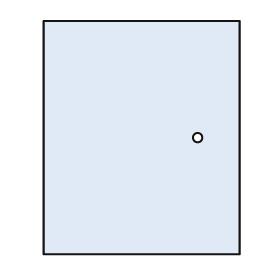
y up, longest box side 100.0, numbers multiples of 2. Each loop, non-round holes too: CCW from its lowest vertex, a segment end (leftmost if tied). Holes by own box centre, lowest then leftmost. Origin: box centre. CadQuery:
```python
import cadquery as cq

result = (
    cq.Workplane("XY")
    .moveTo(-42.0, -50.0)
    .lineTo(42.0, -50.0)
    .lineTo(42.0, 50.0)
    .lineTo(-42.0, 50.0)
    .close()
    .moveTo(24.0, 0.0)
    .circle(2.0)
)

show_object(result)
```